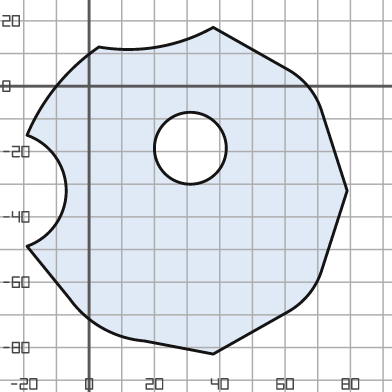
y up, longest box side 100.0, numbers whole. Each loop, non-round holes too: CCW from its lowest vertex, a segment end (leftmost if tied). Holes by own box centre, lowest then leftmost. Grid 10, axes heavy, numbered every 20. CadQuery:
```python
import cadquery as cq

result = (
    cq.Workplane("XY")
    .moveTo(38.0, -82.0)
    .lineTo(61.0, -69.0)
    .threePointArc((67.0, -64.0), (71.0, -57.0))
    .lineTo(79.0, -32.0)
    .lineTo(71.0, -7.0)
    .threePointArc((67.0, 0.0), (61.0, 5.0))
    .lineTo(38.0, 18.0)
    .threePointArc((21.0, 12.0), (3.0, 12.0))
    .threePointArc((-10.0, 0.0), (-19.0, -15.0))
    .threePointArc((-7.0, -32.0), (-19.0, -49.0))
    .lineTo(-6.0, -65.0)
    .threePointArc((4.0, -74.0), (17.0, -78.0))
    .close()
    .moveTo(31.0, -19.0)
    .circle(11.0)
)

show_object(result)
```